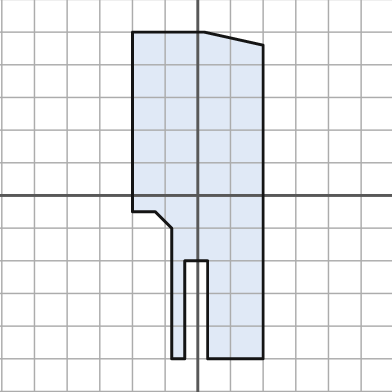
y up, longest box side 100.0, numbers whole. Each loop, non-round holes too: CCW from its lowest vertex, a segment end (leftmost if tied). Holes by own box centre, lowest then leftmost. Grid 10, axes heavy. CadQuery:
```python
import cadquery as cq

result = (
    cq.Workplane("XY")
    .moveTo(-8.0, -50.0)
    .lineTo(-4.0, -50.0)
    .lineTo(-4.0, -20.0)
    .lineTo(3.0, -20.0)
    .lineTo(3.0, -50.0)
    .lineTo(20.0, -50.0)
    .lineTo(20.0, 46.0)
    .lineTo(2.0, 50.0)
    .lineTo(-20.0, 50.0)
    .lineTo(-20.0, -5.0)
    .lineTo(-13.0, -5.0)
    .lineTo(-8.0, -10.0)
    .close()
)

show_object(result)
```